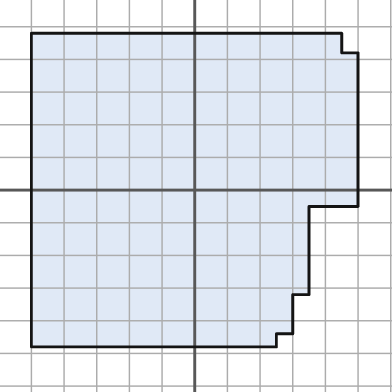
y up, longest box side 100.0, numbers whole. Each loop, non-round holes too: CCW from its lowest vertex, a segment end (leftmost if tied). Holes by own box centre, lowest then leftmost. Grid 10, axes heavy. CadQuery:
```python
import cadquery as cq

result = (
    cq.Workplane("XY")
    .moveTo(-50.0, -48.0)
    .lineTo(25.0, -48.0)
    .lineTo(25.0, -44.0)
    .lineTo(30.0, -44.0)
    .lineTo(30.0, -32.0)
    .lineTo(35.0, -32.0)
    .lineTo(35.0, -5.0)
    .lineTo(50.0, -5.0)
    .lineTo(50.0, 42.0)
    .lineTo(45.0, 42.0)
    .lineTo(45.0, 48.0)
    .lineTo(-50.0, 48.0)
    .close()
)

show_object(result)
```